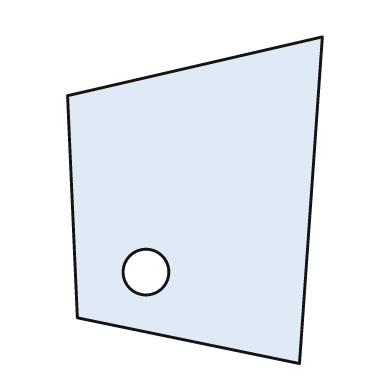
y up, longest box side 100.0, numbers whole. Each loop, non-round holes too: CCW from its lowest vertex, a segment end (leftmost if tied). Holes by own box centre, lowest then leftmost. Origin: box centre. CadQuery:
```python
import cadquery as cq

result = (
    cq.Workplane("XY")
    .moveTo(32.0, -50.0)
    .lineTo(39.0, 50.0)
    .lineTo(-39.0, 32.0)
    .lineTo(-36.0, -36.0)
    .close()
    .moveTo(-15.0, -22.0)
    .circle(7.0)
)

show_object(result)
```